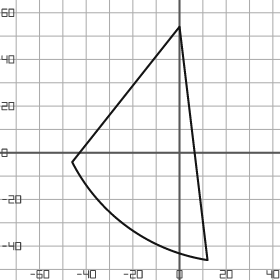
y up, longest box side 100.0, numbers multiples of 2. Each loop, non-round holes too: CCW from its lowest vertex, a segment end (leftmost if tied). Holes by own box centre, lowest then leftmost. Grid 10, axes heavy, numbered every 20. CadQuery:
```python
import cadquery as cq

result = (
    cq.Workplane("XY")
    .moveTo(12.0, -46.0)
    .lineTo(0.0, 54.0)
    .lineTo(-46.0, -4.0)
    .threePointArc((-22.0, -32.0), (12.0, -46.0))
    .close()
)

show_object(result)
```